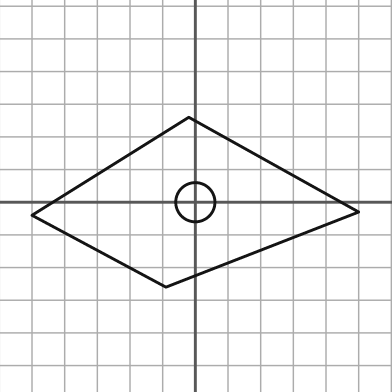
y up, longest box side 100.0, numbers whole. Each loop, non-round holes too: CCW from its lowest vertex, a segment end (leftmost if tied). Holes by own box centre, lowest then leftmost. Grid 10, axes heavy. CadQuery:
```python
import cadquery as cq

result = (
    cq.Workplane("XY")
    .moveTo(-9.0, -26.0)
    .lineTo(50.0, -3.0)
    .lineTo(-2.0, 26.0)
    .lineTo(-50.0, -4.0)
    .close()
    .moveTo(0.0, 0.0)
    .circle(6.0)
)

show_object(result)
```